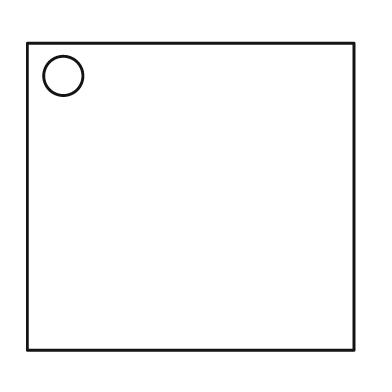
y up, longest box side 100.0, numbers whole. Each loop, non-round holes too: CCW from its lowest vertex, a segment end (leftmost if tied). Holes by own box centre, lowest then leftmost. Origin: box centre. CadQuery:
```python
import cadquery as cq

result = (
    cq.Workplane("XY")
    .moveTo(-50.0, -47.0)
    .lineTo(50.0, -47.0)
    .lineTo(50.0, 47.0)
    .lineTo(-50.0, 47.0)
    .close()
    .moveTo(-39.0, 37.0)
    .circle(6.0)
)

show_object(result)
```